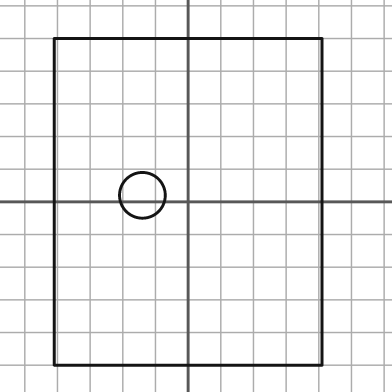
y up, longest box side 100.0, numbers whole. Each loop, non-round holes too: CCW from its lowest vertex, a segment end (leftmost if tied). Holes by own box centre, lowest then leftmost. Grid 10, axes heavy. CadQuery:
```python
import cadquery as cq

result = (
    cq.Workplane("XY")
    .moveTo(-41.0, -50.0)
    .lineTo(41.0, -50.0)
    .lineTo(41.0, 50.0)
    .lineTo(-41.0, 50.0)
    .close()
    .moveTo(-14.0, 2.0)
    .circle(7.0)
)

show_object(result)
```